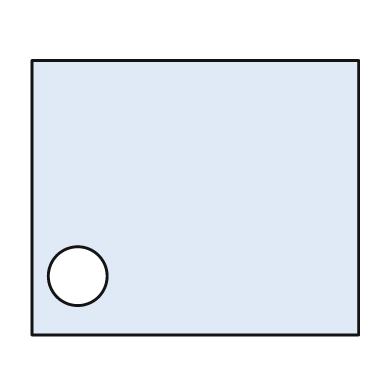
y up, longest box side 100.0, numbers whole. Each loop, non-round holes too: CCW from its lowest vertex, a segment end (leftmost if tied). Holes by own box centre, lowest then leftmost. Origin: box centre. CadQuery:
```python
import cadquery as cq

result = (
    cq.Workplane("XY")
    .moveTo(-50.0, -42.0)
    .lineTo(50.0, -42.0)
    .lineTo(50.0, 42.0)
    .lineTo(-50.0, 42.0)
    .close()
    .moveTo(-36.0, -24.0)
    .circle(9.0)
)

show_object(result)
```